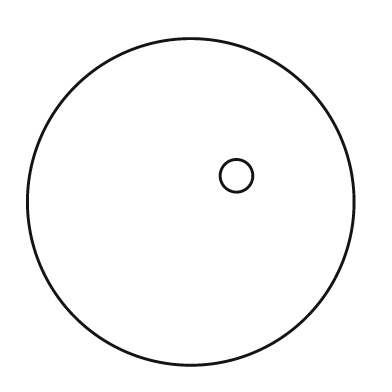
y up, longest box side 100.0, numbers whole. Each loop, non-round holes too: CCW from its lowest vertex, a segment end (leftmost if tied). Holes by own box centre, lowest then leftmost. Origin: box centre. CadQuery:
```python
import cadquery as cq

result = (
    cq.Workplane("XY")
    .moveTo(0.0, 0.0)
    .circle(50.0)
    .moveTo(14.0, 8.0)
    .circle(5.0)
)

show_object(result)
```